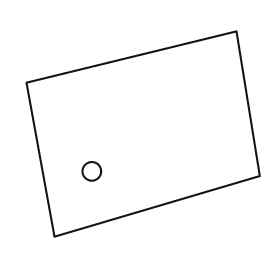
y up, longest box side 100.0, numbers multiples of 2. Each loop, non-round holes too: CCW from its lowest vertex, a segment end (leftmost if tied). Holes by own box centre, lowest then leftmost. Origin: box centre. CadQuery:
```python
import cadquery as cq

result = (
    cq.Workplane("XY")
    .moveTo(-38.0, -44.0)
    .lineTo(50.0, -18.0)
    .lineTo(40.0, 44.0)
    .lineTo(-50.0, 22.0)
    .close()
    .moveTo(-22.0, -16.0)
    .circle(4.0)
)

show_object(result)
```